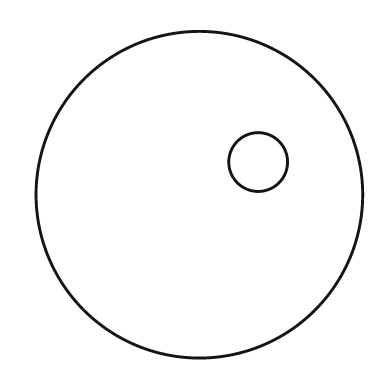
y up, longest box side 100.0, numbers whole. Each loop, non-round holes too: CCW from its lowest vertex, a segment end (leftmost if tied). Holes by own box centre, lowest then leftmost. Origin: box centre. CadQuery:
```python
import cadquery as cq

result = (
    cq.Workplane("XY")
    .moveTo(0.0, 0.0)
    .circle(50.0)
    .moveTo(18.0, 10.0)
    .circle(9.0)
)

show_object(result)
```